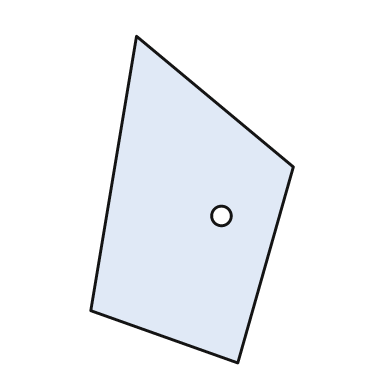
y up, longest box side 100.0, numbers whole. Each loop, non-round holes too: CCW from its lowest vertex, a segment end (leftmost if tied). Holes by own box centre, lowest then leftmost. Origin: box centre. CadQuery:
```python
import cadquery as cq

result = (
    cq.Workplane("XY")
    .moveTo(14.0, -50.0)
    .lineTo(31.0, 10.0)
    .lineTo(-17.0, 50.0)
    .lineTo(-31.0, -34.0)
    .close()
    .moveTo(9.0, -5.0)
    .circle(3.0)
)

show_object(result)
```